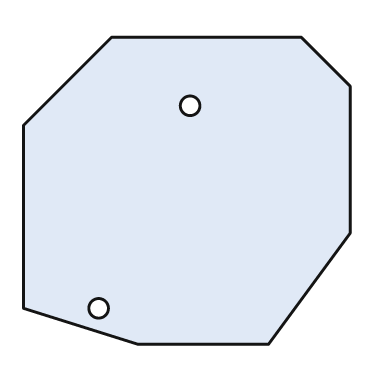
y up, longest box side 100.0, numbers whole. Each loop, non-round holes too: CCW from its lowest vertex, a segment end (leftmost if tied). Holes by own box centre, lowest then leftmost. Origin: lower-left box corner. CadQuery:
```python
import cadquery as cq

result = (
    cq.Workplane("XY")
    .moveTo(35.0, 0.0)
    .lineTo(75.0, 0.0)
    .lineTo(100.0, 34.0)
    .lineTo(100.0, 79.0)
    .lineTo(85.0, 94.0)
    .lineTo(27.0, 94.0)
    .lineTo(0.0, 67.0)
    .lineTo(0.0, 11.0)
    .close()
    .moveTo(23.0, 11.0)
    .circle(3.0)
    .moveTo(51.0, 73.0)
    .circle(3.0)
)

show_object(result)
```